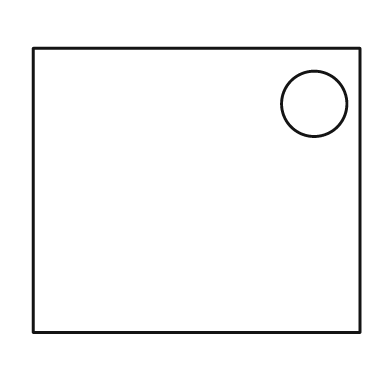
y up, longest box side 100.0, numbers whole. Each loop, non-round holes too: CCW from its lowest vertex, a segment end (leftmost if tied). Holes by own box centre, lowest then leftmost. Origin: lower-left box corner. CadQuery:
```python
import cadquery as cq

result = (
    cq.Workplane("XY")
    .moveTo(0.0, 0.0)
    .lineTo(100.0, 0.0)
    .lineTo(100.0, 87.0)
    .lineTo(0.0, 87.0)
    .close()
    .moveTo(86.0, 70.0)
    .circle(10.0)
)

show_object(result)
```